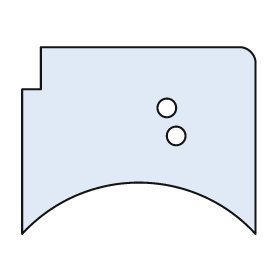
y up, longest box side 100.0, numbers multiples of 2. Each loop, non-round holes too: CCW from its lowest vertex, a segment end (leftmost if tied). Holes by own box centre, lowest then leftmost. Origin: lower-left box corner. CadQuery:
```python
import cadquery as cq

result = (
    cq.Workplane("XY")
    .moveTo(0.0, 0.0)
    .threePointArc((50.0, 22.0), (100.0, 0.0))
    .lineTo(100.0, 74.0)
    .threePointArc((98.0, 78.0), (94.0, 80.0))
    .lineTo(8.0, 80.0)
    .lineTo(8.0, 62.0)
    .lineTo(0.0, 62.0)
    .close()
    .moveTo(66.0, 42.0)
    .circle(4.0)
    .moveTo(62.0, 54.0)
    .circle(4.0)
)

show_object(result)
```